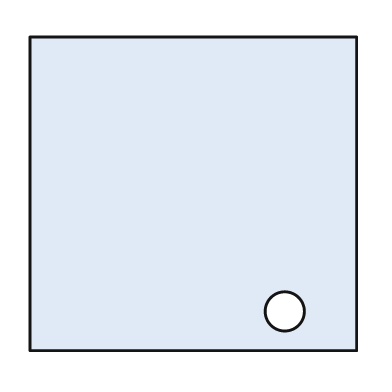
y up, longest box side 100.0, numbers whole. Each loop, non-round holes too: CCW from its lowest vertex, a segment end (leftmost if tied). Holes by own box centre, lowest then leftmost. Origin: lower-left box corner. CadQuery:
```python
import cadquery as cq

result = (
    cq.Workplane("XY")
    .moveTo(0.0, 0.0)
    .lineTo(100.0, 0.0)
    .lineTo(100.0, 96.0)
    .lineTo(0.0, 96.0)
    .close()
    .moveTo(78.0, 12.0)
    .circle(6.0)
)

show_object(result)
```